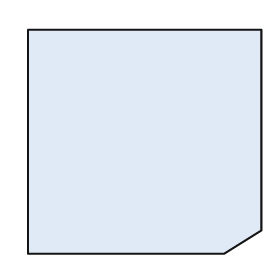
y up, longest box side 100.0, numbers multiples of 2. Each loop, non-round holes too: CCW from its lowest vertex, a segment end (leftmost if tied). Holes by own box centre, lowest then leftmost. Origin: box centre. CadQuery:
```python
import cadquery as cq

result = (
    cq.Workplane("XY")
    .moveTo(-50.0, -48.0)
    .lineTo(34.0, -48.0)
    .lineTo(50.0, -38.0)
    .lineTo(50.0, 48.0)
    .lineTo(-50.0, 48.0)
    .close()
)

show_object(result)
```